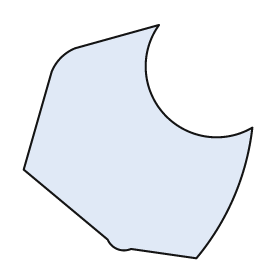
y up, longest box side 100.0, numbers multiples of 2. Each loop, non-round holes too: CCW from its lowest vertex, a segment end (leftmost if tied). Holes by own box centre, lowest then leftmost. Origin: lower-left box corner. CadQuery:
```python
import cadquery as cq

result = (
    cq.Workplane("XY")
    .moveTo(74.0, 0.0)
    .threePointArc((90.0, 26.0), (98.0, 56.0))
    .threePointArc((60.0, 62.0), (58.0, 100.0))
    .lineTo(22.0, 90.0)
    .threePointArc((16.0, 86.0), (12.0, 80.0))
    .lineTo(0.0, 38.0)
    .lineTo(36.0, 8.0)
    .threePointArc((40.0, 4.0), (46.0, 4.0))
    .close()
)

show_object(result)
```